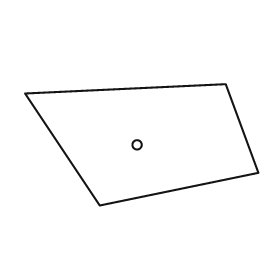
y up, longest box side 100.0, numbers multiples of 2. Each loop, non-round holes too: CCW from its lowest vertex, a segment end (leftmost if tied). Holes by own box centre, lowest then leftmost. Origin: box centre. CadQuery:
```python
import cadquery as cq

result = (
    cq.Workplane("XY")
    .moveTo(-18.0, -26.0)
    .lineTo(50.0, -12.0)
    .lineTo(36.0, 26.0)
    .lineTo(-50.0, 22.0)
    .close()
    .moveTo(-2.0, 0.0)
    .circle(2.0)
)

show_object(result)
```